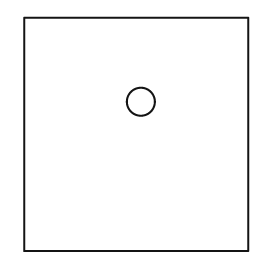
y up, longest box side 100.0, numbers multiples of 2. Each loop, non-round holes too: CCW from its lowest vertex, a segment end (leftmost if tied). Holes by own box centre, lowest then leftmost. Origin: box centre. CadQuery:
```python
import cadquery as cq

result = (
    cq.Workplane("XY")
    .moveTo(-48.0, -50.0)
    .lineTo(48.0, -50.0)
    .lineTo(48.0, 50.0)
    .lineTo(-48.0, 50.0)
    .close()
    .moveTo(2.0, 14.0)
    .circle(6.0)
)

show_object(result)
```